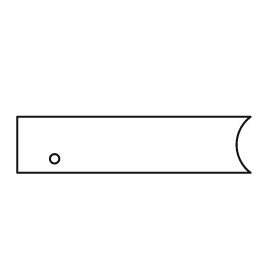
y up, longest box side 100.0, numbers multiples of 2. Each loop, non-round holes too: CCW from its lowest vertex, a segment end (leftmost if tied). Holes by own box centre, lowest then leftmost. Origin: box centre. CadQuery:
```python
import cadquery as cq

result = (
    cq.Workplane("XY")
    .moveTo(-50.0, -12.0)
    .lineTo(50.0, -12.0)
    .threePointArc((44.0, 0.0), (50.0, 12.0))
    .lineTo(-50.0, 12.0)
    .close()
    .moveTo(-34.0, -6.0)
    .circle(2.0)
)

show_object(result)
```